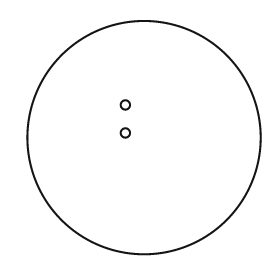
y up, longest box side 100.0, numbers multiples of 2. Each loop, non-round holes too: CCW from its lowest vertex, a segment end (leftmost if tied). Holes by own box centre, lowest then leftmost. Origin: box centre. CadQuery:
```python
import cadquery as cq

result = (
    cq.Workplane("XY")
    .moveTo(0.0, 0.0)
    .circle(50.0)
    .moveTo(-8.0, 2.0)
    .circle(2.0)
    .moveTo(-8.0, 14.0)
    .circle(2.0)
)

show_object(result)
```